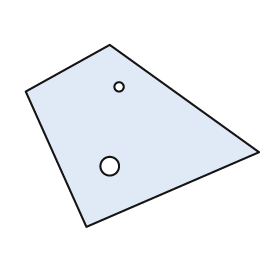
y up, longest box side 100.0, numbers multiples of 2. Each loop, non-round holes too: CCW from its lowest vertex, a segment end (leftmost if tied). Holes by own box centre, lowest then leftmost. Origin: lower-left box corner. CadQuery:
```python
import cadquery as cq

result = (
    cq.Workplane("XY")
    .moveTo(26.0, 0.0)
    .lineTo(100.0, 32.0)
    .lineTo(36.0, 78.0)
    .lineTo(0.0, 58.0)
    .close()
    .moveTo(36.0, 26.0)
    .circle(4.0)
    .moveTo(40.0, 60.0)
    .circle(2.0)
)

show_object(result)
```